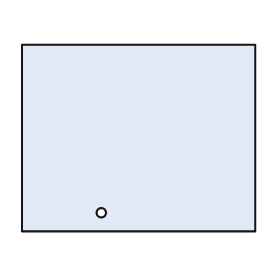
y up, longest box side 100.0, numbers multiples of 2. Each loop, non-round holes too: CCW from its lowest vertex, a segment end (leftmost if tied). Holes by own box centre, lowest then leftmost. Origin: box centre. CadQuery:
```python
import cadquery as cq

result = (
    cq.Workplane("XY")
    .moveTo(-50.0, -40.0)
    .lineTo(50.0, -40.0)
    .lineTo(50.0, 40.0)
    .lineTo(-50.0, 40.0)
    .close()
    .moveTo(-16.0, -32.0)
    .circle(2.0)
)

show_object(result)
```